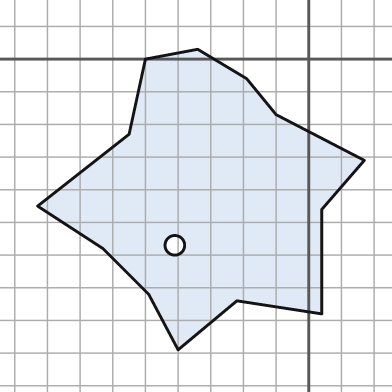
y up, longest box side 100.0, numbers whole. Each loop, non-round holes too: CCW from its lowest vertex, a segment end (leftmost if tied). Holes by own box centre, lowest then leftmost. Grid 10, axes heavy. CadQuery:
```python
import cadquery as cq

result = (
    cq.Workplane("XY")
    .moveTo(-40.0, -89.0)
    .lineTo(-22.0, -74.0)
    .lineTo(4.0, -78.0)
    .lineTo(4.0, -46.0)
    .lineTo(17.0, -31.0)
    .lineTo(-10.0, -17.0)
    .lineTo(-19.0, -6.0)
    .lineTo(-34.0, 3.0)
    .lineTo(-50.0, 0.0)
    .lineTo(-55.0, -23.0)
    .lineTo(-83.0, -45.0)
    .lineTo(-63.0, -58.0)
    .lineTo(-49.0, -72.0)
    .close()
    .moveTo(-41.0, -57.0)
    .circle(3.0)
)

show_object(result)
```